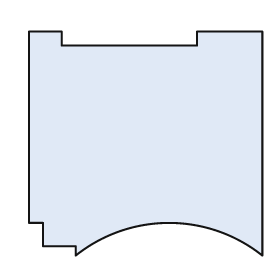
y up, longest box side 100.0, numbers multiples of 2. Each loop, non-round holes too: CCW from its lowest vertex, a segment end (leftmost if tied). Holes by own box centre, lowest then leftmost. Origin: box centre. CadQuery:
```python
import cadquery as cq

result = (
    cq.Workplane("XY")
    .moveTo(-30.0, -48.0)
    .threePointArc((10.0, -34.0), (50.0, -48.0))
    .lineTo(50.0, 48.0)
    .lineTo(22.0, 48.0)
    .lineTo(22.0, 42.0)
    .lineTo(-36.0, 42.0)
    .lineTo(-36.0, 48.0)
    .lineTo(-50.0, 48.0)
    .lineTo(-50.0, -34.0)
    .lineTo(-44.0, -34.0)
    .lineTo(-44.0, -44.0)
    .lineTo(-30.0, -44.0)
    .close()
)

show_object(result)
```